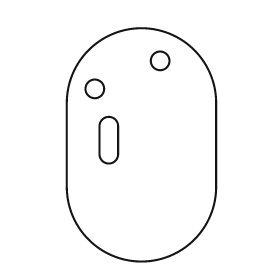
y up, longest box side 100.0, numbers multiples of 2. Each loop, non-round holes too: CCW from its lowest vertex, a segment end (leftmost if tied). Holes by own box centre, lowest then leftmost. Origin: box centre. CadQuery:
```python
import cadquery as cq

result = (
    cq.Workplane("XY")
    .moveTo(-32.0, -18.0)
    .threePointArc((0.0, -50.0), (32.0, -18.0))
    .lineTo(32.0, 18.0)
    .threePointArc((0.0, 50.0), (-32.0, 18.0))
    .close()
    .moveTo(-18.0, -4.0)
    .threePointArc((-14.0, -8.0), (-10.0, -4.0))
    .lineTo(-10.0, 8.0)
    .threePointArc((-14.0, 12.0), (-18.0, 8.0))
    .close()
    .moveTo(-20.0, 24.0)
    .circle(4.0)
    .moveTo(8.0, 36.0)
    .circle(4.0)
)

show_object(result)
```